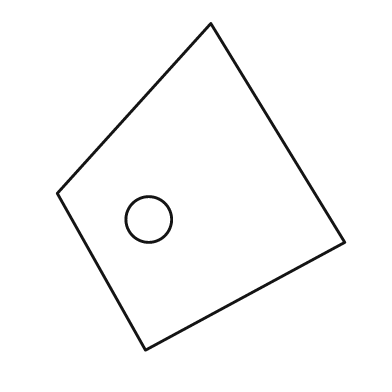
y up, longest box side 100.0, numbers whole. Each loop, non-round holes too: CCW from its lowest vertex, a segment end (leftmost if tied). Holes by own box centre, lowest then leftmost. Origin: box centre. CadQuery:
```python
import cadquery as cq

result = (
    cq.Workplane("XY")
    .moveTo(-17.0, -50.0)
    .lineTo(44.0, -17.0)
    .lineTo(3.0, 50.0)
    .lineTo(-44.0, -2.0)
    .close()
    .moveTo(-16.0, -10.0)
    .circle(7.0)
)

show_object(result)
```